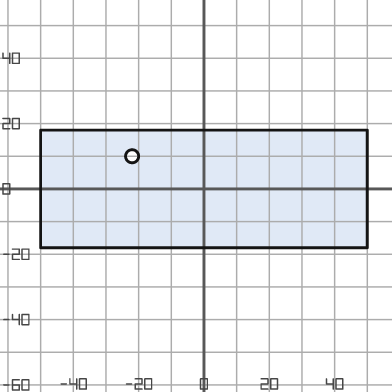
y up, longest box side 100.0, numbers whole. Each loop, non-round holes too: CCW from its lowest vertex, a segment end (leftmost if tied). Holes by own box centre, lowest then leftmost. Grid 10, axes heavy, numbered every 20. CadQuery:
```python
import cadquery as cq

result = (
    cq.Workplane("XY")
    .moveTo(-50.0, -18.0)
    .lineTo(50.0, -18.0)
    .lineTo(50.0, 18.0)
    .lineTo(-50.0, 18.0)
    .close()
    .moveTo(-22.0, 10.0)
    .circle(2.0)
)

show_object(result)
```